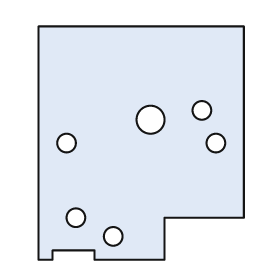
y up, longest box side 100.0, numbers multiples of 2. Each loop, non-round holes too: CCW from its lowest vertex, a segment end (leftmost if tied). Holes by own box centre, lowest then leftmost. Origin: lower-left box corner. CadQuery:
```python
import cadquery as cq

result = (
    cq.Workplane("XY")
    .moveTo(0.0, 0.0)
    .lineTo(6.0, 0.0)
    .lineTo(6.0, 4.0)
    .lineTo(24.0, 4.0)
    .lineTo(24.0, 0.0)
    .lineTo(54.0, 0.0)
    .lineTo(54.0, 18.0)
    .lineTo(88.0, 18.0)
    .lineTo(88.0, 100.0)
    .lineTo(0.0, 100.0)
    .close()
    .moveTo(32.0, 10.0)
    .circle(4.0)
    .moveTo(16.0, 18.0)
    .circle(4.0)
    .moveTo(12.0, 50.0)
    .circle(4.0)
    .moveTo(76.0, 50.0)
    .circle(4.0)
    .moveTo(48.0, 60.0)
    .circle(6.0)
    .moveTo(70.0, 64.0)
    .circle(4.0)
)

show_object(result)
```